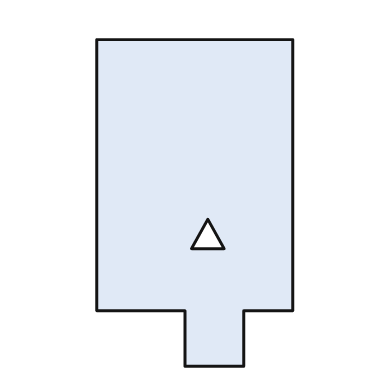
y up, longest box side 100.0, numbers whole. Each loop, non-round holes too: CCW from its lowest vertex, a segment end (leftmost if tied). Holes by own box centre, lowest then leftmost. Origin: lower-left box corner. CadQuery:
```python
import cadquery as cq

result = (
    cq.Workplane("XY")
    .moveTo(27.0, 0.0)
    .lineTo(45.0, 0.0)
    .lineTo(45.0, 17.0)
    .lineTo(60.0, 17.0)
    .lineTo(60.0, 100.0)
    .lineTo(0.0, 100.0)
    .lineTo(0.0, 17.0)
    .lineTo(27.0, 17.0)
    .close()
    .moveTo(29.0, 36.0)
    .lineTo(39.0, 36.0)
    .lineTo(34.0, 45.0)
    .close()
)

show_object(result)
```